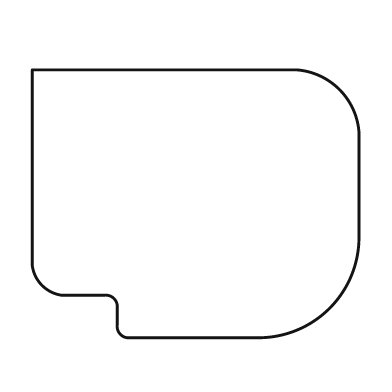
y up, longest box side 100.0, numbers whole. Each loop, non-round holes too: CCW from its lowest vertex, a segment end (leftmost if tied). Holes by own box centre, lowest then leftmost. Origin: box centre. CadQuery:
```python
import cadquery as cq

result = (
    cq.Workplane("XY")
    .moveTo(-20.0, -41.0)
    .lineTo(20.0, -41.0)
    .threePointArc((41.0, -32.0), (50.0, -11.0))
    .lineTo(50.0, 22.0)
    .threePointArc((44.0, 35.0), (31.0, 41.0))
    .lineTo(-50.0, 41.0)
    .lineTo(-50.0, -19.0)
    .threePointArc((-47.0, -25.0), (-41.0, -28.0))
    .lineTo(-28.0, -28.0)
    .threePointArc((-25.0, -29.0), (-24.0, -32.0))
    .lineTo(-24.0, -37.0)
    .threePointArc((-23.0, -40.0), (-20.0, -41.0))
    .close()
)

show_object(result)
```